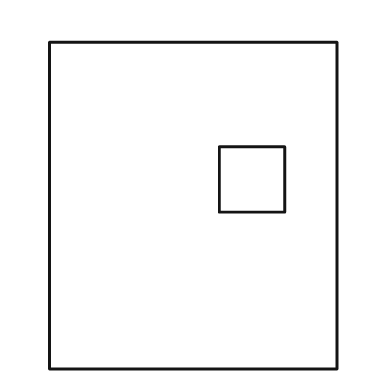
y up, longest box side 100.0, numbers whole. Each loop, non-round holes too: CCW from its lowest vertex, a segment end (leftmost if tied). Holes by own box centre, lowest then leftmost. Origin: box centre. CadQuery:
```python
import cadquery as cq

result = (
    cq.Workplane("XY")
    .moveTo(-44.0, -50.0)
    .lineTo(44.0, -50.0)
    .lineTo(44.0, 50.0)
    .lineTo(-44.0, 50.0)
    .close()
    .moveTo(8.0, -2.0)
    .lineTo(28.0, -2.0)
    .lineTo(28.0, 18.0)
    .lineTo(8.0, 18.0)
    .close()
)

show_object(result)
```